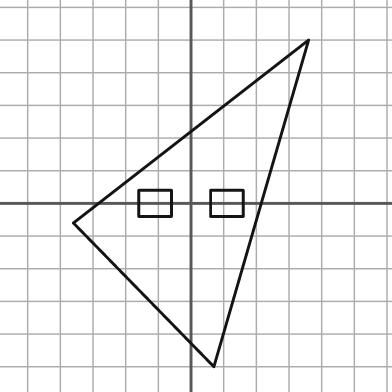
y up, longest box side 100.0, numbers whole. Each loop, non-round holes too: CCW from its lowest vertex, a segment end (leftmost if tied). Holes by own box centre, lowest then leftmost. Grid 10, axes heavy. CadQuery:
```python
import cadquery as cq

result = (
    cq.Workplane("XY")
    .moveTo(7.0, -50.0)
    .lineTo(36.0, 50.0)
    .lineTo(-36.0, -6.0)
    .close()
    .moveTo(-16.0, -4.0)
    .lineTo(-6.0, -4.0)
    .lineTo(-6.0, 4.0)
    .lineTo(-16.0, 4.0)
    .close()
    .moveTo(6.0, -4.0)
    .lineTo(16.0, -4.0)
    .lineTo(16.0, 4.0)
    .lineTo(6.0, 4.0)
    .close()
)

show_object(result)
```